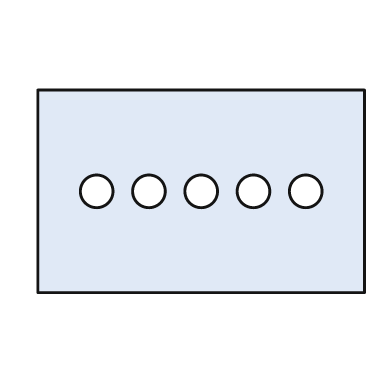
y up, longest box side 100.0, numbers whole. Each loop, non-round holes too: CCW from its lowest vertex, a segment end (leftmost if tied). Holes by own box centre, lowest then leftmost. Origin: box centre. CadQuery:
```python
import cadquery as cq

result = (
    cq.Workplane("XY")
    .moveTo(-50.0, -31.0)
    .lineTo(50.0, -31.0)
    .lineTo(50.0, 31.0)
    .lineTo(-50.0, 31.0)
    .close()
    .moveTo(-32.0, 0.0)
    .circle(5.0)
    .moveTo(-16.0, 0.0)
    .circle(5.0)
    .moveTo(0.0, 0.0)
    .circle(5.0)
    .moveTo(16.0, 0.0)
    .circle(5.0)
    .moveTo(32.0, 0.0)
    .circle(5.0)
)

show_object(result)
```